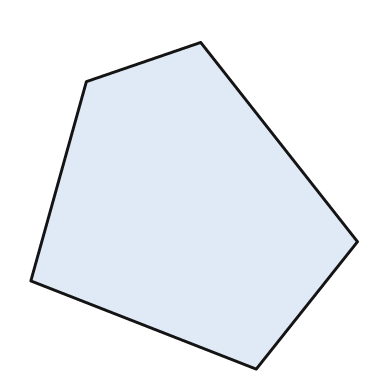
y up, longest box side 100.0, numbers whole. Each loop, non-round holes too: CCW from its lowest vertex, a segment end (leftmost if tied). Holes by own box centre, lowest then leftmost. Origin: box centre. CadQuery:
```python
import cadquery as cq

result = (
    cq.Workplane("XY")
    .moveTo(19.0, -50.0)
    .lineTo(50.0, -11.0)
    .lineTo(2.0, 50.0)
    .lineTo(-33.0, 38.0)
    .lineTo(-50.0, -23.0)
    .close()
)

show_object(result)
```